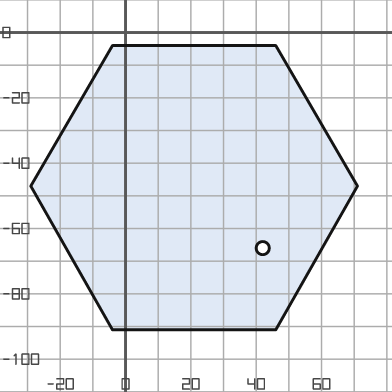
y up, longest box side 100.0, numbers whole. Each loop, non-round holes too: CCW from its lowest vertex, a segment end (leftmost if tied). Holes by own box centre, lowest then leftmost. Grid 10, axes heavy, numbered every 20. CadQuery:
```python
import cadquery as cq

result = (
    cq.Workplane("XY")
    .moveTo(-4.0, -91.0)
    .lineTo(46.0, -91.0)
    .lineTo(71.0, -47.0)
    .lineTo(46.0, -4.0)
    .lineTo(-4.0, -4.0)
    .lineTo(-29.0, -47.0)
    .close()
    .moveTo(42.0, -66.0)
    .circle(2.0)
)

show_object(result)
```